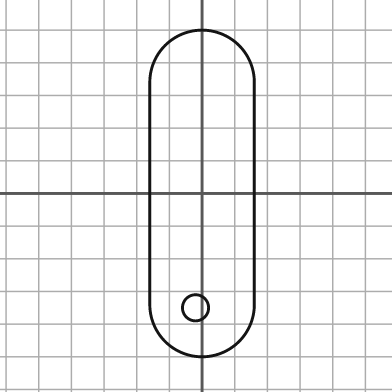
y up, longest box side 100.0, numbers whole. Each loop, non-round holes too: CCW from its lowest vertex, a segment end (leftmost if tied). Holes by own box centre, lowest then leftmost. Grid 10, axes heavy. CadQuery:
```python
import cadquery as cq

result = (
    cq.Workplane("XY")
    .moveTo(-16.0, -34.0)
    .threePointArc((0.0, -50.0), (16.0, -34.0))
    .lineTo(16.0, 34.0)
    .threePointArc((0.0, 50.0), (-16.0, 34.0))
    .close()
    .moveTo(-2.0, -35.0)
    .circle(4.0)
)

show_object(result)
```